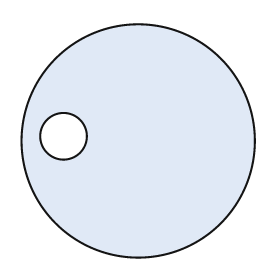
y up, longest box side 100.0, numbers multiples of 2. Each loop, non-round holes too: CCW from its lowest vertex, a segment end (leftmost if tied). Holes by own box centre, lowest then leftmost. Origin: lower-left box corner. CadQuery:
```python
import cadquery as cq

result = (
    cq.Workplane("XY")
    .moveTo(50.0, 50.0)
    .circle(50.0)
    .moveTo(18.0, 52.0)
    .circle(10.0)
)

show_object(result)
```